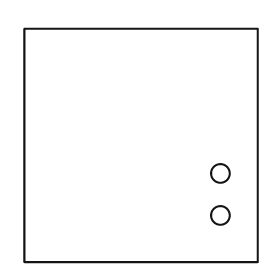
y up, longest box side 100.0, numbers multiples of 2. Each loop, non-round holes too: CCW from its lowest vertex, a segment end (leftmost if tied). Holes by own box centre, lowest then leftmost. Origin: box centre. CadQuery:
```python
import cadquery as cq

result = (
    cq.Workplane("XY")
    .moveTo(-50.0, -50.0)
    .lineTo(50.0, -50.0)
    .lineTo(50.0, 50.0)
    .lineTo(-50.0, 50.0)
    .close()
    .moveTo(34.0, -30.0)
    .circle(4.0)
    .moveTo(34.0, -12.0)
    .circle(4.0)
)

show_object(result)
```